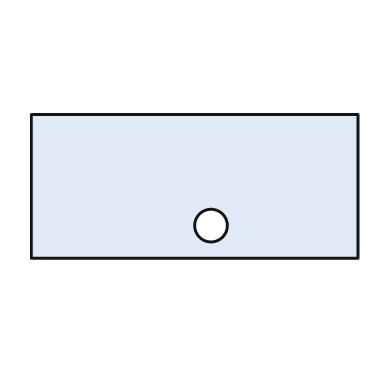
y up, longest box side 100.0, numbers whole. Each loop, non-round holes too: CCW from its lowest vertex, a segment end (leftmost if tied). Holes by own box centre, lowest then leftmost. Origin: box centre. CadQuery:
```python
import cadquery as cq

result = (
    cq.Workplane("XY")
    .moveTo(-50.0, -22.0)
    .lineTo(50.0, -22.0)
    .lineTo(50.0, 22.0)
    .lineTo(-50.0, 22.0)
    .close()
    .moveTo(5.0, -12.0)
    .circle(5.0)
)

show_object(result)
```